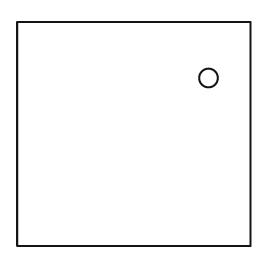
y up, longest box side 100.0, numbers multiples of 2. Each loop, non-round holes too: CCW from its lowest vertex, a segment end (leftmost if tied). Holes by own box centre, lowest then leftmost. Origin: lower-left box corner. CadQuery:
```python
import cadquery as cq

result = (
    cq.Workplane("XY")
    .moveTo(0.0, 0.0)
    .lineTo(100.0, 0.0)
    .lineTo(100.0, 96.0)
    .lineTo(0.0, 96.0)
    .close()
    .moveTo(82.0, 72.0)
    .circle(4.0)
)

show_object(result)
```